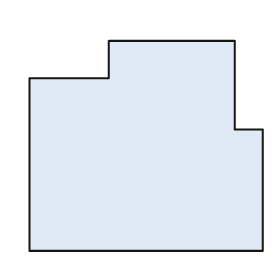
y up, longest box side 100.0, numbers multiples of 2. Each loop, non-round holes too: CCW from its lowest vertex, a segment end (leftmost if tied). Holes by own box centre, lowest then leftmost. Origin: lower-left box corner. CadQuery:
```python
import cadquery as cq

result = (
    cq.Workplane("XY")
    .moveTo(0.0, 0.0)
    .lineTo(100.0, 0.0)
    .lineTo(100.0, 52.0)
    .lineTo(88.0, 52.0)
    .lineTo(88.0, 90.0)
    .lineTo(34.0, 90.0)
    .lineTo(34.0, 74.0)
    .lineTo(0.0, 74.0)
    .close()
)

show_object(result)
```